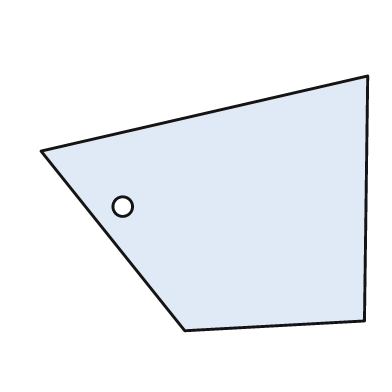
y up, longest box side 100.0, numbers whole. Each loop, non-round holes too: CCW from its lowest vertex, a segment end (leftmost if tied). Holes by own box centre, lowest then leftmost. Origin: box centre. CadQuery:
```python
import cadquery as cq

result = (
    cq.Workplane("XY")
    .moveTo(-6.0, -39.0)
    .lineTo(49.0, -36.0)
    .lineTo(50.0, 39.0)
    .lineTo(-50.0, 16.0)
    .close()
    .moveTo(-25.0, -1.0)
    .circle(3.0)
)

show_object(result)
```